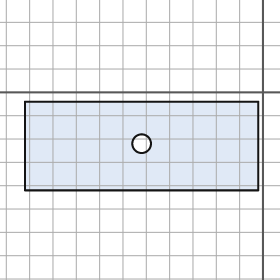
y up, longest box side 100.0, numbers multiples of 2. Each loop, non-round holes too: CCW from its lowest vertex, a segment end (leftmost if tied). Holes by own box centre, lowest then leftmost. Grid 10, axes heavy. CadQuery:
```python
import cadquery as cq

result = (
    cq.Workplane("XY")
    .moveTo(-102.0, -42.0)
    .lineTo(-2.0, -42.0)
    .lineTo(-2.0, -4.0)
    .lineTo(-102.0, -4.0)
    .close()
    .moveTo(-52.0, -22.0)
    .circle(4.0)
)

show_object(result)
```